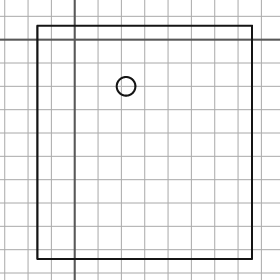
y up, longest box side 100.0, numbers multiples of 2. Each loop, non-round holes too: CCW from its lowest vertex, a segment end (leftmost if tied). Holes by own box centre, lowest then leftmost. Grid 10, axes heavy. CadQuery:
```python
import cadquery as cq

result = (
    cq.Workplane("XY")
    .moveTo(-16.0, -94.0)
    .lineTo(76.0, -94.0)
    .lineTo(76.0, 6.0)
    .lineTo(-16.0, 6.0)
    .close()
    .moveTo(22.0, -20.0)
    .circle(4.0)
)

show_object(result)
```